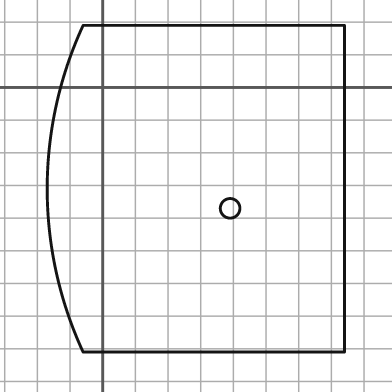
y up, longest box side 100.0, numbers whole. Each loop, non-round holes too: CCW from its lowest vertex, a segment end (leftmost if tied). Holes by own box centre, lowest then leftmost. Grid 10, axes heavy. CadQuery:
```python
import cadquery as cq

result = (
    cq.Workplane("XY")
    .moveTo(-6.0, -81.0)
    .lineTo(74.0, -81.0)
    .lineTo(74.0, 19.0)
    .lineTo(-6.0, 19.0)
    .threePointArc((-17.0, -31.0), (-6.0, -81.0))
    .close()
    .moveTo(39.0, -37.0)
    .circle(3.0)
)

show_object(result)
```